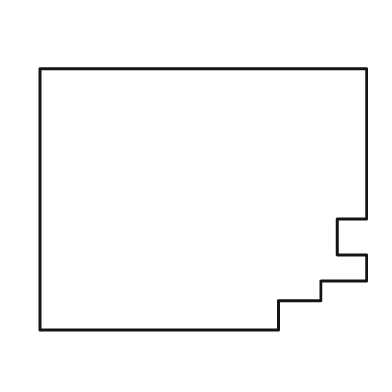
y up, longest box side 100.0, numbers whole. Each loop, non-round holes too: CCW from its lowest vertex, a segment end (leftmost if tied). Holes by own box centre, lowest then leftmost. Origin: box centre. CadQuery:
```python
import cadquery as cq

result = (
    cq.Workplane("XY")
    .moveTo(-50.0, -40.0)
    .lineTo(23.0, -40.0)
    .lineTo(23.0, -31.0)
    .lineTo(36.0, -31.0)
    .lineTo(36.0, -25.0)
    .lineTo(50.0, -25.0)
    .lineTo(50.0, -17.0)
    .lineTo(41.0, -17.0)
    .lineTo(41.0, -6.0)
    .lineTo(50.0, -6.0)
    .lineTo(50.0, 40.0)
    .lineTo(-50.0, 40.0)
    .close()
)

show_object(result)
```